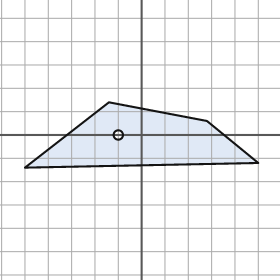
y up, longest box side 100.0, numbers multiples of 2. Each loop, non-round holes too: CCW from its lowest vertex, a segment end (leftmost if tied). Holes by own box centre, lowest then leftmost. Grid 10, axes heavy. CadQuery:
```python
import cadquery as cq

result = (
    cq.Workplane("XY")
    .moveTo(-50.0, -14.0)
    .lineTo(50.0, -12.0)
    .lineTo(28.0, 6.0)
    .lineTo(-14.0, 14.0)
    .close()
    .moveTo(-10.0, 0.0)
    .circle(2.0)
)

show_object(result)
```